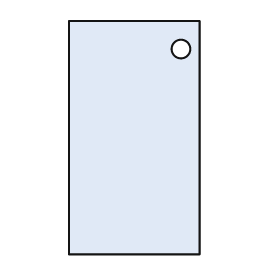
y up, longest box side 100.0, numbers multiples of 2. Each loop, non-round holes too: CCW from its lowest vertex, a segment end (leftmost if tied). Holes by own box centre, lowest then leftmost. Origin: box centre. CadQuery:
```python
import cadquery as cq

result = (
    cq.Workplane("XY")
    .moveTo(-28.0, -50.0)
    .lineTo(28.0, -50.0)
    .lineTo(28.0, 50.0)
    .lineTo(-28.0, 50.0)
    .close()
    .moveTo(20.0, 38.0)
    .circle(4.0)
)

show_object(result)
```